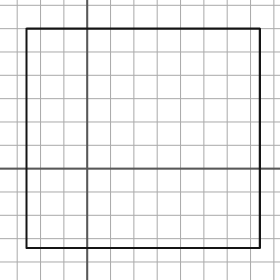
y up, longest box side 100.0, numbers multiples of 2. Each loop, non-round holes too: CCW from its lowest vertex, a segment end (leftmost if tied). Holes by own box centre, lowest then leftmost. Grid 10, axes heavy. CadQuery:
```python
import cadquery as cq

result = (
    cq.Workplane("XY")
    .moveTo(-26.0, -34.0)
    .lineTo(74.0, -34.0)
    .lineTo(74.0, 60.0)
    .lineTo(-26.0, 60.0)
    .close()
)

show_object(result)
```